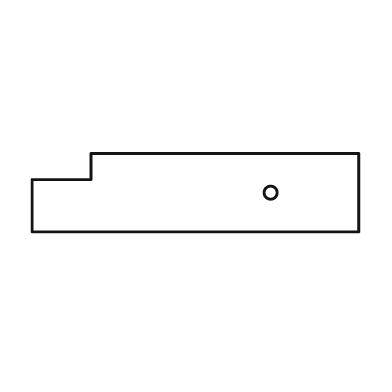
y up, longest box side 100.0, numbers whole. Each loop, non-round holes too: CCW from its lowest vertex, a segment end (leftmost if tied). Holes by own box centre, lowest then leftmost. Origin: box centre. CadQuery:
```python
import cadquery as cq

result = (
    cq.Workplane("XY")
    .moveTo(-50.0, -12.0)
    .lineTo(50.0, -12.0)
    .lineTo(50.0, 12.0)
    .lineTo(-32.0, 12.0)
    .lineTo(-32.0, 4.0)
    .lineTo(-50.0, 4.0)
    .close()
    .moveTo(23.0, 0.0)
    .circle(2.0)
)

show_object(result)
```